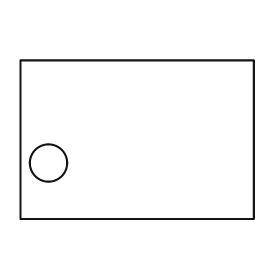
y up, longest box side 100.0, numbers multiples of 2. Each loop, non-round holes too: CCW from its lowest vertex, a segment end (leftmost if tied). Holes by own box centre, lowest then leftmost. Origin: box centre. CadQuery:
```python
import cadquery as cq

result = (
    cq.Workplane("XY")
    .moveTo(-50.0, -34.0)
    .lineTo(50.0, -34.0)
    .lineTo(50.0, 34.0)
    .lineTo(-50.0, 34.0)
    .close()
    .moveTo(-38.0, -10.0)
    .circle(8.0)
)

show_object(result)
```